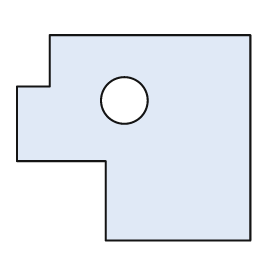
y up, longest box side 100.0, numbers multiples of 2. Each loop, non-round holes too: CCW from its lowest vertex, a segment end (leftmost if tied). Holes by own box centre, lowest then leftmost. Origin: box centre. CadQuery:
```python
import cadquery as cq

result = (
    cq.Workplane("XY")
    .moveTo(-12.0, -44.0)
    .lineTo(50.0, -44.0)
    .lineTo(50.0, 44.0)
    .lineTo(-36.0, 44.0)
    .lineTo(-36.0, 22.0)
    .lineTo(-50.0, 22.0)
    .lineTo(-50.0, -10.0)
    .lineTo(-12.0, -10.0)
    .close()
    .moveTo(-4.0, 16.0)
    .circle(10.0)
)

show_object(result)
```